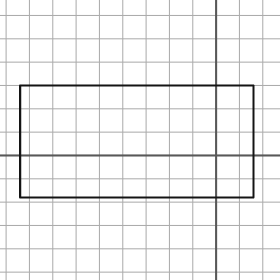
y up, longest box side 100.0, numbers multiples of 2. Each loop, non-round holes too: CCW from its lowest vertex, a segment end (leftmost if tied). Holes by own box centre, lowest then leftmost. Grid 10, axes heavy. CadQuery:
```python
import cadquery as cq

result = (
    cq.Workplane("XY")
    .moveTo(-84.0, -18.0)
    .lineTo(16.0, -18.0)
    .lineTo(16.0, 30.0)
    .lineTo(-84.0, 30.0)
    .close()
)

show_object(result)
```